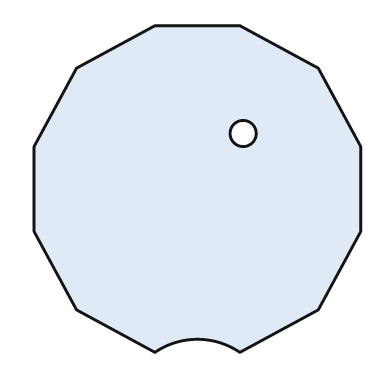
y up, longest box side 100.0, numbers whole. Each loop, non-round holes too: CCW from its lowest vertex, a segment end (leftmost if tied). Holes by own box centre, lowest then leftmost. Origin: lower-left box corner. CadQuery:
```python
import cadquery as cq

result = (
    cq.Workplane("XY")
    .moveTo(37.0, 0.0)
    .threePointArc((50.0, 4.0), (63.0, 0.0))
    .lineTo(87.0, 13.0)
    .lineTo(100.0, 37.0)
    .lineTo(100.0, 63.0)
    .lineTo(87.0, 87.0)
    .lineTo(63.0, 100.0)
    .lineTo(37.0, 100.0)
    .lineTo(13.0, 87.0)
    .lineTo(0.0, 63.0)
    .lineTo(0.0, 37.0)
    .lineTo(13.0, 13.0)
    .close()
    .moveTo(64.0, 67.0)
    .circle(4.0)
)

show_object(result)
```